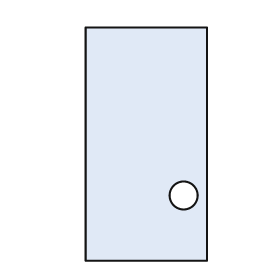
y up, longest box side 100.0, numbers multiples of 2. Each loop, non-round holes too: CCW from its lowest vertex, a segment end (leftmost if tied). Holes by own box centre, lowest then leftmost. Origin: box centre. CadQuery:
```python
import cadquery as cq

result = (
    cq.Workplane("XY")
    .moveTo(-26.0, -50.0)
    .lineTo(26.0, -50.0)
    .lineTo(26.0, 50.0)
    .lineTo(-26.0, 50.0)
    .close()
    .moveTo(16.0, -22.0)
    .circle(6.0)
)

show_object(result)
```